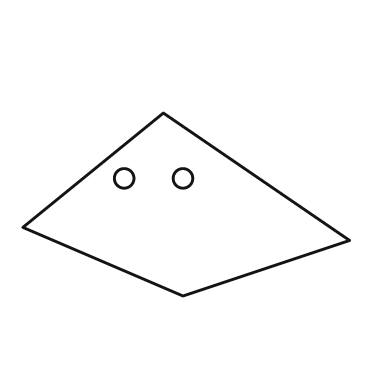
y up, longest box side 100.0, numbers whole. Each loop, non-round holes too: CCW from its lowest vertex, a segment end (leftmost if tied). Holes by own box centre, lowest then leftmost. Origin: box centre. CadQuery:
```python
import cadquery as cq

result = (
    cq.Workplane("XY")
    .moveTo(-1.0, -28.0)
    .lineTo(50.0, -11.0)
    .lineTo(-7.0, 28.0)
    .lineTo(-50.0, -7.0)
    .close()
    .moveTo(-19.0, 8.0)
    .circle(3.0)
    .moveTo(-1.0, 8.0)
    .circle(3.0)
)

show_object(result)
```